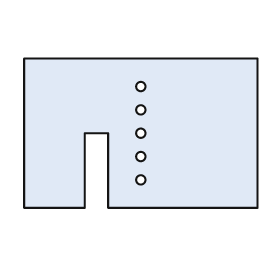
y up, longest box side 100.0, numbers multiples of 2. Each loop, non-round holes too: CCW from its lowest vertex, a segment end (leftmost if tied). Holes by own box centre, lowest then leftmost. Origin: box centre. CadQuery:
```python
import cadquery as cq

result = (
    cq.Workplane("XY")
    .moveTo(-50.0, -32.0)
    .lineTo(-24.0, -32.0)
    .lineTo(-24.0, 0.0)
    .lineTo(-14.0, 0.0)
    .lineTo(-14.0, -32.0)
    .lineTo(50.0, -32.0)
    .lineTo(50.0, 32.0)
    .lineTo(-50.0, 32.0)
    .close()
    .moveTo(0.0, -20.0)
    .circle(2.0)
    .moveTo(0.0, -10.0)
    .circle(2.0)
    .moveTo(0.0, 0.0)
    .circle(2.0)
    .moveTo(0.0, 10.0)
    .circle(2.0)
    .moveTo(0.0, 20.0)
    .circle(2.0)
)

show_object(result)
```